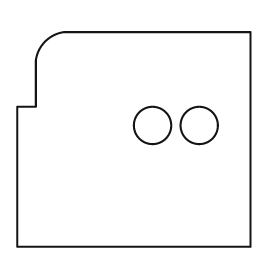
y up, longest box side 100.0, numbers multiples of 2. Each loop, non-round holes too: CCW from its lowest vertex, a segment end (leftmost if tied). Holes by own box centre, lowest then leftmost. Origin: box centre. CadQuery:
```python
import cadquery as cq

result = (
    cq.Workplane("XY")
    .moveTo(-50.0, -46.0)
    .lineTo(50.0, -46.0)
    .lineTo(50.0, 46.0)
    .lineTo(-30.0, 46.0)
    .threePointArc((-38.0, 42.0), (-42.0, 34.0))
    .lineTo(-42.0, 14.0)
    .lineTo(-50.0, 14.0)
    .close()
    .moveTo(8.0, 6.0)
    .circle(8.0)
    .moveTo(28.0, 6.0)
    .circle(8.0)
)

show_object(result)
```